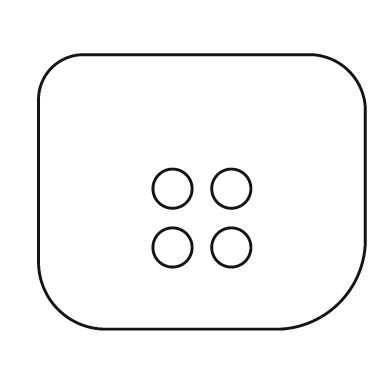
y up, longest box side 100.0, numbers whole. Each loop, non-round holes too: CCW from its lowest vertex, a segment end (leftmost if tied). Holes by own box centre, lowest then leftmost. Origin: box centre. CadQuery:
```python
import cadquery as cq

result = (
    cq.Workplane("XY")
    .moveTo(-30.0, -42.0)
    .lineTo(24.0, -42.0)
    .threePointArc((42.0, -34.0), (50.0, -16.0))
    .lineTo(50.0, 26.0)
    .threePointArc((45.0, 37.0), (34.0, 42.0))
    .lineTo(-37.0, 42.0)
    .threePointArc((-46.0, 38.0), (-50.0, 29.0))
    .lineTo(-50.0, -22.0)
    .threePointArc((-44.0, -36.0), (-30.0, -42.0))
    .close()
    .moveTo(-9.0, -17.0)
    .circle(6.0)
    .moveTo(9.0, -17.0)
    .circle(6.0)
    .moveTo(-9.0, 1.0)
    .circle(6.0)
    .moveTo(9.0, 1.0)
    .circle(6.0)
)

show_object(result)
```